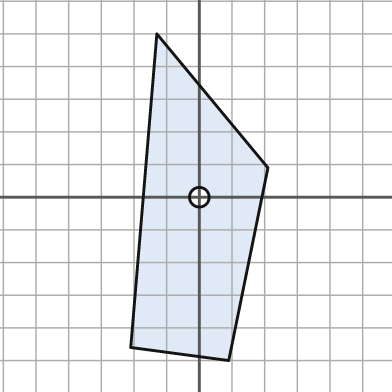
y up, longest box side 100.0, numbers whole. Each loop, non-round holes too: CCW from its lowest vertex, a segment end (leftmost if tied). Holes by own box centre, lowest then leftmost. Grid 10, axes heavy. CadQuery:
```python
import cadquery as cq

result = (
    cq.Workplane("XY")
    .moveTo(9.0, -50.0)
    .lineTo(21.0, 9.0)
    .lineTo(-13.0, 50.0)
    .lineTo(-21.0, -46.0)
    .close()
    .moveTo(0.0, 0.0)
    .circle(3.0)
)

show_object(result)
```